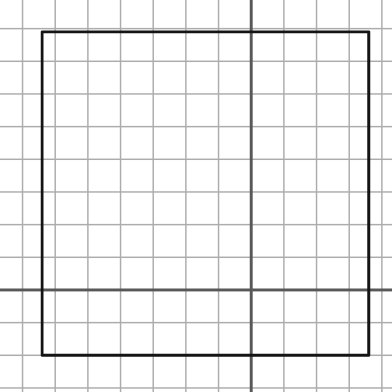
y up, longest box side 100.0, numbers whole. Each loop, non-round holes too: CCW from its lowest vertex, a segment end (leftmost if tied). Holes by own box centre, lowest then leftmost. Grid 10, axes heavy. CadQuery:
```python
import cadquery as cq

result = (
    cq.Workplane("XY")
    .moveTo(-64.0, -20.0)
    .lineTo(36.0, -20.0)
    .lineTo(36.0, 79.0)
    .lineTo(-64.0, 79.0)
    .close()
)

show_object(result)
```